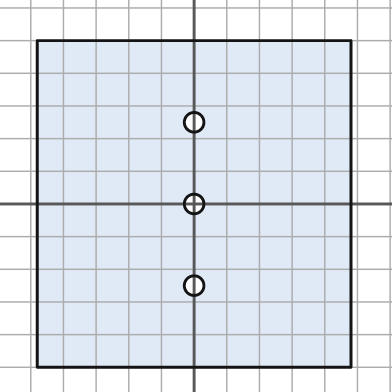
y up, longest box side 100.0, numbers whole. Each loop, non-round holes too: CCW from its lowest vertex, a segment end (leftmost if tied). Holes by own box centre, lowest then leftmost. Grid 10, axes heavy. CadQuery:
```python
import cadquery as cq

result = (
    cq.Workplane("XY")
    .moveTo(-48.0, -50.0)
    .lineTo(48.0, -50.0)
    .lineTo(48.0, 50.0)
    .lineTo(-48.0, 50.0)
    .close()
    .moveTo(0.0, -25.0)
    .circle(3.0)
    .moveTo(0.0, 0.0)
    .circle(3.0)
    .moveTo(0.0, 25.0)
    .circle(3.0)
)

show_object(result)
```